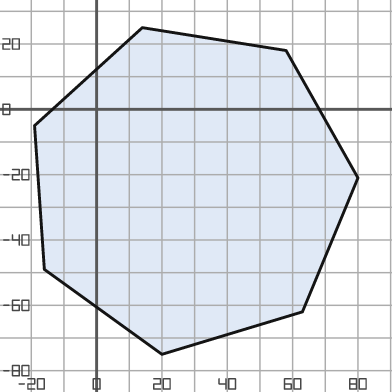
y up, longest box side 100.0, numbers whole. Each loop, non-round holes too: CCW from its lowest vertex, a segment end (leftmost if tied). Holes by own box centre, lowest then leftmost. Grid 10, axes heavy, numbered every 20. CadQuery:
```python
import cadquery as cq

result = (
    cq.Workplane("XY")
    .moveTo(20.0, -75.0)
    .lineTo(63.0, -62.0)
    .lineTo(80.0, -21.0)
    .lineTo(58.0, 18.0)
    .lineTo(14.0, 25.0)
    .lineTo(-19.0, -5.0)
    .lineTo(-16.0, -49.0)
    .close()
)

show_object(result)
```